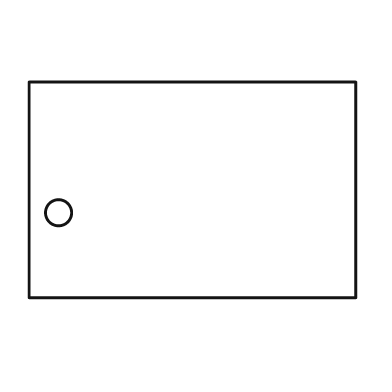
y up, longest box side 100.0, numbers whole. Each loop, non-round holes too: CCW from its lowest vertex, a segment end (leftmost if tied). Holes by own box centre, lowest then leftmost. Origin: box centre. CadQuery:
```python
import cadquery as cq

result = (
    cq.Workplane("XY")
    .moveTo(-50.0, -33.0)
    .lineTo(50.0, -33.0)
    .lineTo(50.0, 33.0)
    .lineTo(-50.0, 33.0)
    .close()
    .moveTo(-41.0, -7.0)
    .circle(4.0)
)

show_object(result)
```